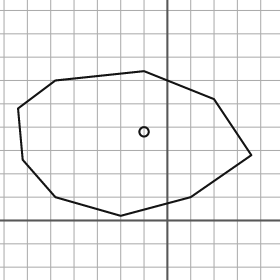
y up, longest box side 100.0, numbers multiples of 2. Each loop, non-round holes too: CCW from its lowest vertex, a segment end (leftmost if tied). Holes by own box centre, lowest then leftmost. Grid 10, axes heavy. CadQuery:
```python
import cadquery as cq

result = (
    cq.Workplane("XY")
    .moveTo(-20.0, 2.0)
    .lineTo(10.0, 10.0)
    .lineTo(36.0, 28.0)
    .lineTo(20.0, 52.0)
    .lineTo(-10.0, 64.0)
    .lineTo(-48.0, 60.0)
    .lineTo(-64.0, 48.0)
    .lineTo(-62.0, 26.0)
    .lineTo(-48.0, 10.0)
    .close()
    .moveTo(-10.0, 38.0)
    .circle(2.0)
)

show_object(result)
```